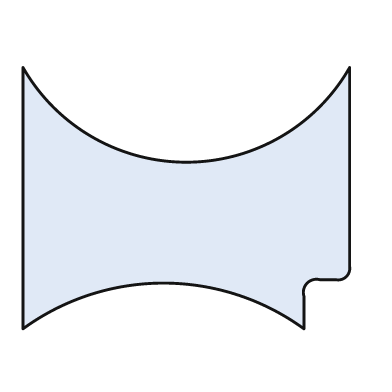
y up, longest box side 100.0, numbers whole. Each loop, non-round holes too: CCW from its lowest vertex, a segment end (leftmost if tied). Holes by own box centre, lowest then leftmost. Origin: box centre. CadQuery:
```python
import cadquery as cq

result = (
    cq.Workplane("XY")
    .moveTo(-50.0, -40.0)
    .threePointArc((-7.0, -26.0), (36.0, -40.0))
    .lineTo(36.0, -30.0)
    .threePointArc((37.0, -26.0), (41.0, -25.0))
    .lineTo(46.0, -25.0)
    .threePointArc((49.0, -24.0), (50.0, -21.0))
    .lineTo(50.0, 40.0)
    .threePointArc((0.0, 11.0), (-50.0, 40.0))
    .close()
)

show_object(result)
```